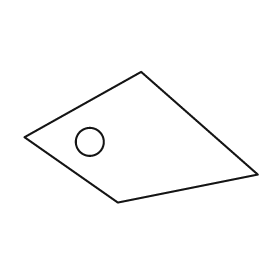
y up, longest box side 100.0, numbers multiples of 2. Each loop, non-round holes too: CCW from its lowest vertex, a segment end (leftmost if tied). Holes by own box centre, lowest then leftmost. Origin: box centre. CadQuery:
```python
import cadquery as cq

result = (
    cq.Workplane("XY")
    .moveTo(-10.0, -28.0)
    .lineTo(50.0, -16.0)
    .lineTo(0.0, 28.0)
    .lineTo(-50.0, 0.0)
    .close()
    .moveTo(-22.0, -2.0)
    .circle(6.0)
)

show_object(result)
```